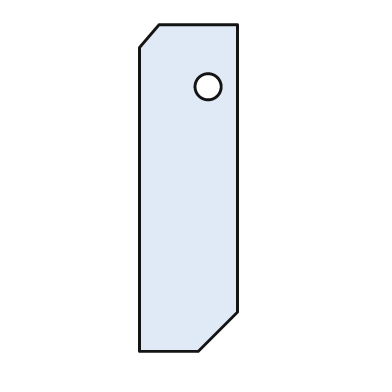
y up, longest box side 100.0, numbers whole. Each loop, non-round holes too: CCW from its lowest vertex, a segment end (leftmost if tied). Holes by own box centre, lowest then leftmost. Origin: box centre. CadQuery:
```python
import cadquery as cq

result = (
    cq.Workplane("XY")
    .moveTo(-15.0, -50.0)
    .lineTo(3.0, -50.0)
    .lineTo(15.0, -38.0)
    .lineTo(15.0, 50.0)
    .lineTo(-9.0, 50.0)
    .lineTo(-15.0, 43.0)
    .close()
    .moveTo(6.0, 31.0)
    .circle(4.0)
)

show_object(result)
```